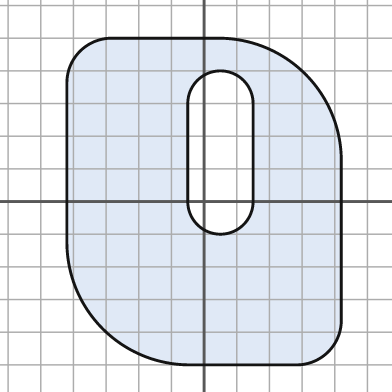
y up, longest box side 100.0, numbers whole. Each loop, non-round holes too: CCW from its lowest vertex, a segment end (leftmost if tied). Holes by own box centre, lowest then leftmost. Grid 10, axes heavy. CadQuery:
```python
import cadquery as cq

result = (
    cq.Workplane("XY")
    .moveTo(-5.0, -50.0)
    .lineTo(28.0, -50.0)
    .threePointArc((38.0, -46.0), (42.0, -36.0))
    .lineTo(42.0, 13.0)
    .threePointArc((31.0, 39.0), (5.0, 50.0))
    .lineTo(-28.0, 50.0)
    .threePointArc((-38.0, 46.0), (-42.0, 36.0))
    .lineTo(-42.0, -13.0)
    .threePointArc((-31.0, -39.0), (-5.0, -50.0))
    .close()
    .moveTo(-5.0, 0.0)
    .threePointArc((5.0, -10.0), (15.0, 0.0))
    .lineTo(15.0, 30.0)
    .threePointArc((5.0, 40.0), (-5.0, 30.0))
    .close()
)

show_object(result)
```